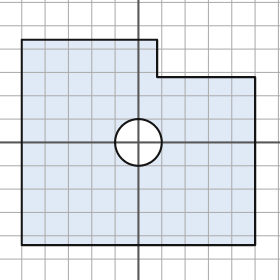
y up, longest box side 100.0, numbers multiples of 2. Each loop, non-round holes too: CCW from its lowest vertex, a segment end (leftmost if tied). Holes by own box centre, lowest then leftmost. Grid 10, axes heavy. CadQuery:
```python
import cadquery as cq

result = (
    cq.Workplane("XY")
    .moveTo(-50.0, -44.0)
    .lineTo(50.0, -44.0)
    .lineTo(50.0, 28.0)
    .lineTo(8.0, 28.0)
    .lineTo(8.0, 44.0)
    .lineTo(-50.0, 44.0)
    .close()
    .moveTo(0.0, 0.0)
    .circle(10.0)
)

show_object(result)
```